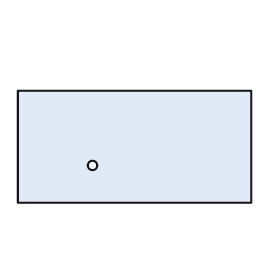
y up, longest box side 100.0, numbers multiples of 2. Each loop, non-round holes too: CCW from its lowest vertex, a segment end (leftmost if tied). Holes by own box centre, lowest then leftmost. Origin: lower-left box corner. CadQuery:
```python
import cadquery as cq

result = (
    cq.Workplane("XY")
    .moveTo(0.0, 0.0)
    .lineTo(100.0, 0.0)
    .lineTo(100.0, 48.0)
    .lineTo(0.0, 48.0)
    .close()
    .moveTo(32.0, 16.0)
    .circle(2.0)
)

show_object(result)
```